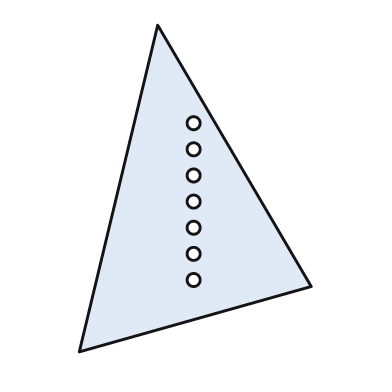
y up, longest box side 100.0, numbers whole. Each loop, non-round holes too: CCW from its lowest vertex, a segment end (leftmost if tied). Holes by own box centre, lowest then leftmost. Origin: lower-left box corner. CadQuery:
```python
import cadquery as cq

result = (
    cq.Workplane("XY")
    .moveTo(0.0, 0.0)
    .lineTo(71.0, 20.0)
    .lineTo(24.0, 100.0)
    .close()
    .moveTo(35.0, 22.0)
    .circle(2.0)
    .moveTo(35.0, 30.0)
    .circle(2.0)
    .moveTo(35.0, 38.0)
    .circle(2.0)
    .moveTo(35.0, 46.0)
    .circle(2.0)
    .moveTo(35.0, 54.0)
    .circle(2.0)
    .moveTo(35.0, 62.0)
    .circle(2.0)
    .moveTo(35.0, 70.0)
    .circle(2.0)
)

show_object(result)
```